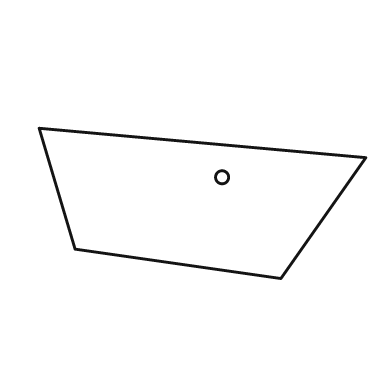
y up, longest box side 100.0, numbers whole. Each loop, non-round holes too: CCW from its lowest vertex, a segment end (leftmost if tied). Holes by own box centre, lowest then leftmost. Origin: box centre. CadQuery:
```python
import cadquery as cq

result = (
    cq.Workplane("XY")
    .moveTo(24.0, -23.0)
    .lineTo(50.0, 14.0)
    .lineTo(-50.0, 23.0)
    .lineTo(-39.0, -14.0)
    .close()
    .moveTo(6.0, 8.0)
    .circle(2.0)
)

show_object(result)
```